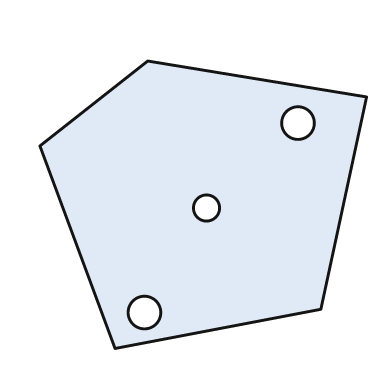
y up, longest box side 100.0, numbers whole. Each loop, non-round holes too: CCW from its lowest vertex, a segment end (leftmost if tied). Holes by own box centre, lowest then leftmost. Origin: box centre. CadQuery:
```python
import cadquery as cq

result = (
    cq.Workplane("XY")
    .moveTo(-27.0, -44.0)
    .lineTo(36.0, -32.0)
    .lineTo(50.0, 33.0)
    .lineTo(-17.0, 44.0)
    .lineTo(-50.0, 18.0)
    .close()
    .moveTo(-18.0, -33.0)
    .circle(5.0)
    .moveTo(1.0, -1.0)
    .circle(4.0)
    .moveTo(29.0, 25.0)
    .circle(5.0)
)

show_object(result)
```